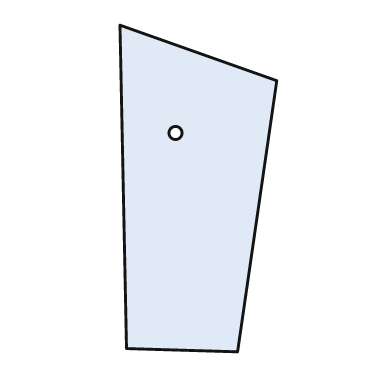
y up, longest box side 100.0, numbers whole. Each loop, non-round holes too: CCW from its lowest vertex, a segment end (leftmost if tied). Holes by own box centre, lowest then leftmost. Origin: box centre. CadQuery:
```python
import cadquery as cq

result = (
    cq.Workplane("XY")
    .moveTo(12.0, -50.0)
    .lineTo(24.0, 33.0)
    .lineTo(-24.0, 50.0)
    .lineTo(-22.0, -49.0)
    .close()
    .moveTo(-7.0, 17.0)
    .circle(2.0)
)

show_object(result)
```